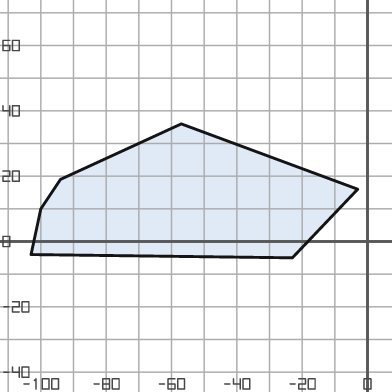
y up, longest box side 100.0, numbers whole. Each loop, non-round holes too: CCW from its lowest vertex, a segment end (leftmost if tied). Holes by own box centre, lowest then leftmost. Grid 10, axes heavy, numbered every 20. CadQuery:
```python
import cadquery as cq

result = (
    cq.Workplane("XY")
    .moveTo(-23.0, -5.0)
    .lineTo(-3.0, 16.0)
    .lineTo(-57.0, 36.0)
    .lineTo(-94.0, 19.0)
    .lineTo(-100.0, 10.0)
    .lineTo(-103.0, -4.0)
    .close()
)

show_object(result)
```